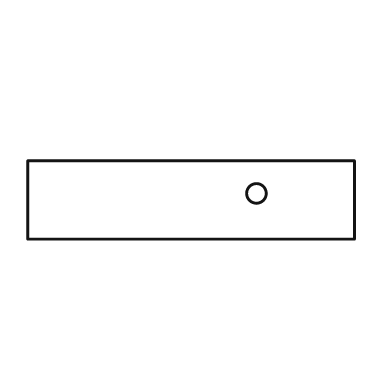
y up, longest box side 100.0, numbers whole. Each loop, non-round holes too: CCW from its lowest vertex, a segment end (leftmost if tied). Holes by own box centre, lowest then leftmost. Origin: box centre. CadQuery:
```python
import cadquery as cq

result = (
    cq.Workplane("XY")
    .moveTo(-50.0, -12.0)
    .lineTo(50.0, -12.0)
    .lineTo(50.0, 12.0)
    .lineTo(-50.0, 12.0)
    .close()
    .moveTo(20.0, 2.0)
    .circle(3.0)
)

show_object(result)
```